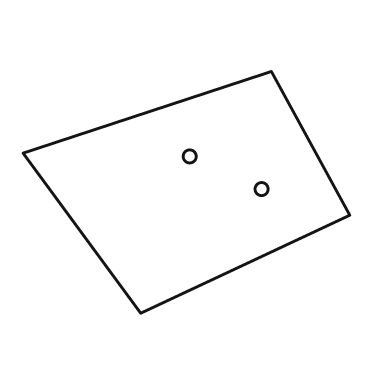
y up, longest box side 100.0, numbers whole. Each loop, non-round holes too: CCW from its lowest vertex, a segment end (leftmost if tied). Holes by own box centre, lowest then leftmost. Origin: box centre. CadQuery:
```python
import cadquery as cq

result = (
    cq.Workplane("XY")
    .moveTo(-14.0, -37.0)
    .lineTo(50.0, -7.0)
    .lineTo(26.0, 37.0)
    .lineTo(-50.0, 12.0)
    .close()
    .moveTo(23.0, 1.0)
    .circle(2.0)
    .moveTo(1.0, 11.0)
    .circle(2.0)
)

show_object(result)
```